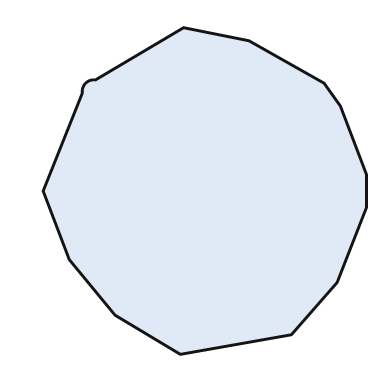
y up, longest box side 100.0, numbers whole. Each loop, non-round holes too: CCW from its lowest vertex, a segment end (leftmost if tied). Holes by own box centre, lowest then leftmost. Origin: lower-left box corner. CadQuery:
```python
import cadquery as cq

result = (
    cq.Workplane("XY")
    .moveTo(42.0, 0.0)
    .lineTo(76.0, 6.0)
    .lineTo(90.0, 22.0)
    .lineTo(99.0, 45.0)
    .lineTo(99.0, 55.0)
    .lineTo(91.0, 76.0)
    .lineTo(86.0, 83.0)
    .lineTo(63.0, 96.0)
    .lineTo(43.0, 100.0)
    .lineTo(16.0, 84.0)
    .threePointArc((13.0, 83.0), (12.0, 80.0))
    .lineTo(0.0, 50.0)
    .lineTo(8.0, 29.0)
    .lineTo(22.0, 12.0)
    .close()
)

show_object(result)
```